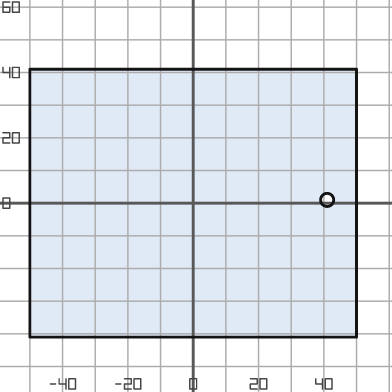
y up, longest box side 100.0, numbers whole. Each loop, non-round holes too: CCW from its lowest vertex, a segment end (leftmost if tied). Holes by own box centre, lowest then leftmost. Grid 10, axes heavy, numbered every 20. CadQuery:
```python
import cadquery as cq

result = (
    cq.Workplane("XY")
    .moveTo(-50.0, -41.0)
    .lineTo(50.0, -41.0)
    .lineTo(50.0, 41.0)
    .lineTo(-50.0, 41.0)
    .close()
    .moveTo(41.0, 1.0)
    .circle(2.0)
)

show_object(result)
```